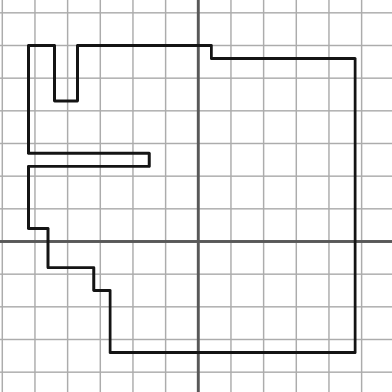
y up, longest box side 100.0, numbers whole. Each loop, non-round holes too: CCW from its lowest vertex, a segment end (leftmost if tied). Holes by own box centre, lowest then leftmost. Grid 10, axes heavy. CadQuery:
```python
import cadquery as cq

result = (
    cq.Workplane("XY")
    .moveTo(-27.0, -34.0)
    .lineTo(48.0, -34.0)
    .lineTo(48.0, 56.0)
    .lineTo(4.0, 56.0)
    .lineTo(4.0, 60.0)
    .lineTo(-37.0, 60.0)
    .lineTo(-37.0, 43.0)
    .lineTo(-44.0, 43.0)
    .lineTo(-44.0, 60.0)
    .lineTo(-52.0, 60.0)
    .lineTo(-52.0, 27.0)
    .lineTo(-15.0, 27.0)
    .lineTo(-15.0, 23.0)
    .lineTo(-52.0, 23.0)
    .lineTo(-52.0, 4.0)
    .lineTo(-46.0, 4.0)
    .lineTo(-46.0, -8.0)
    .lineTo(-32.0, -8.0)
    .lineTo(-32.0, -15.0)
    .lineTo(-27.0, -15.0)
    .close()
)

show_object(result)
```